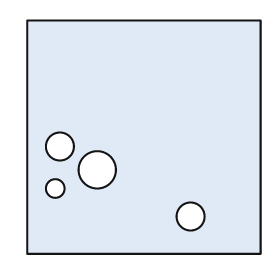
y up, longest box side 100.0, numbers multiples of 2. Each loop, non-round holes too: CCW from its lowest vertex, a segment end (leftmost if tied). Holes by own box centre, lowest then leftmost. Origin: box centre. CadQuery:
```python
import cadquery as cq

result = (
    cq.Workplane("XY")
    .moveTo(-50.0, -50.0)
    .lineTo(50.0, -50.0)
    .lineTo(50.0, 50.0)
    .lineTo(-50.0, 50.0)
    .close()
    .moveTo(20.0, -34.0)
    .circle(6.0)
    .moveTo(-38.0, -22.0)
    .circle(4.0)
    .moveTo(-20.0, -14.0)
    .circle(8.0)
    .moveTo(-36.0, -4.0)
    .circle(6.0)
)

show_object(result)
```